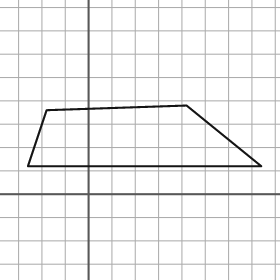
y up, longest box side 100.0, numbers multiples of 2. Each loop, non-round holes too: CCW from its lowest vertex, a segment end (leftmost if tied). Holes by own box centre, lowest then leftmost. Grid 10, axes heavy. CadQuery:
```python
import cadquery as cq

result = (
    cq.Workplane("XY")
    .moveTo(-26.0, 12.0)
    .lineTo(74.0, 12.0)
    .lineTo(42.0, 38.0)
    .lineTo(-18.0, 36.0)
    .close()
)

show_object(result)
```